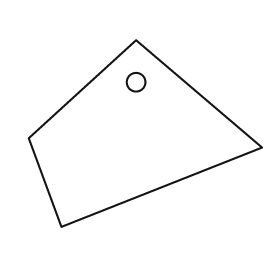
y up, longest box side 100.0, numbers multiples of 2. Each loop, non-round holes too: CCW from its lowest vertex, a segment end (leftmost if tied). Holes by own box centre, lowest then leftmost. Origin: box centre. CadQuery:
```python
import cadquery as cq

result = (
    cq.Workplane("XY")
    .moveTo(-36.0, -40.0)
    .lineTo(50.0, -6.0)
    .lineTo(-4.0, 40.0)
    .lineTo(-50.0, -2.0)
    .close()
    .moveTo(-4.0, 22.0)
    .circle(4.0)
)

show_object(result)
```